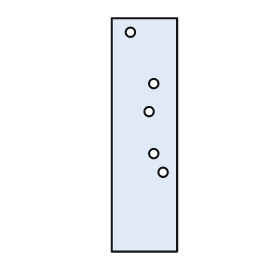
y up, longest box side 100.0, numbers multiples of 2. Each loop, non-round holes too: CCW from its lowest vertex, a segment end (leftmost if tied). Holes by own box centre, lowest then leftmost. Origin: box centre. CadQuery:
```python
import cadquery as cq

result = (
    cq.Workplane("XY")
    .moveTo(-14.0, -50.0)
    .lineTo(14.0, -50.0)
    .lineTo(14.0, 50.0)
    .lineTo(-14.0, 50.0)
    .close()
    .moveTo(8.0, -16.0)
    .circle(2.0)
    .moveTo(4.0, -8.0)
    .circle(2.0)
    .moveTo(2.0, 10.0)
    .circle(2.0)
    .moveTo(4.0, 22.0)
    .circle(2.0)
    .moveTo(-6.0, 44.0)
    .circle(2.0)
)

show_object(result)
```